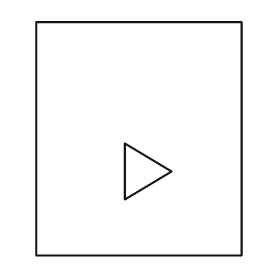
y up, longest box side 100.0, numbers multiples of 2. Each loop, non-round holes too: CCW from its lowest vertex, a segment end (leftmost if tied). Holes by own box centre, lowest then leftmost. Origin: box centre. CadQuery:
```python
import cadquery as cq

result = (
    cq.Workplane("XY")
    .moveTo(-44.0, -50.0)
    .lineTo(44.0, -50.0)
    .lineTo(44.0, 50.0)
    .lineTo(-44.0, 50.0)
    .close()
    .moveTo(-6.0, -26.0)
    .lineTo(14.0, -14.0)
    .lineTo(-6.0, -2.0)
    .close()
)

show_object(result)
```